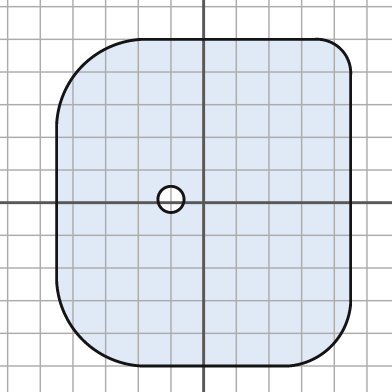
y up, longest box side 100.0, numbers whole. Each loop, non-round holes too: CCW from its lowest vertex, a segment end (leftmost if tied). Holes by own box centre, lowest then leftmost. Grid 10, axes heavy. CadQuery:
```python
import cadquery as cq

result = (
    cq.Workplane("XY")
    .moveTo(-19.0, -50.0)
    .lineTo(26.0, -50.0)
    .threePointArc((39.0, -44.0), (45.0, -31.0))
    .lineTo(45.0, 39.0)
    .threePointArc((42.0, 47.0), (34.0, 50.0))
    .lineTo(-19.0, 50.0)
    .threePointArc((-37.0, 42.0), (-45.0, 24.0))
    .lineTo(-45.0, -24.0)
    .threePointArc((-37.0, -42.0), (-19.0, -50.0))
    .close()
    .moveTo(-10.0, 1.0)
    .circle(4.0)
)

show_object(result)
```